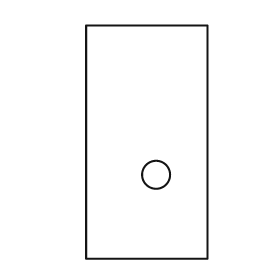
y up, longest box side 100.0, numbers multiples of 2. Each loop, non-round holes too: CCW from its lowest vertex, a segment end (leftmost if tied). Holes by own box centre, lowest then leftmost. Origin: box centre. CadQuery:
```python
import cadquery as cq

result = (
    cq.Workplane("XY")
    .moveTo(-26.0, -50.0)
    .lineTo(26.0, -50.0)
    .lineTo(26.0, 50.0)
    .lineTo(-26.0, 50.0)
    .close()
    .moveTo(4.0, -14.0)
    .circle(6.0)
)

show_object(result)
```